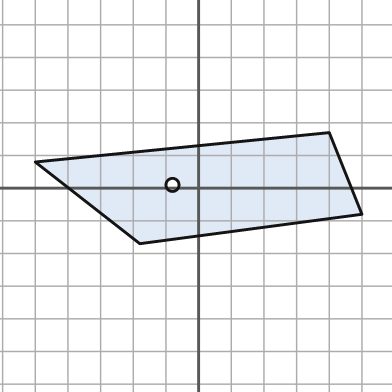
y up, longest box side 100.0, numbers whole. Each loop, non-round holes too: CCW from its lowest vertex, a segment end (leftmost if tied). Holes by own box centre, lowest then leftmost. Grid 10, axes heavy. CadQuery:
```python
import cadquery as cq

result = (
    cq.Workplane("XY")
    .moveTo(-18.0, -17.0)
    .lineTo(50.0, -8.0)
    .lineTo(40.0, 17.0)
    .lineTo(-50.0, 8.0)
    .close()
    .moveTo(-8.0, 1.0)
    .circle(2.0)
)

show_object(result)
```